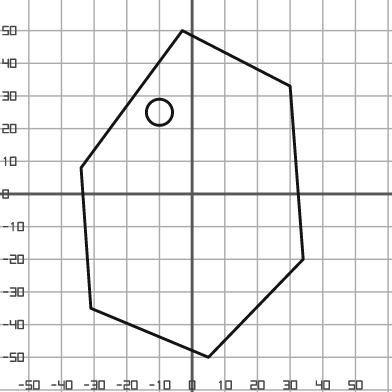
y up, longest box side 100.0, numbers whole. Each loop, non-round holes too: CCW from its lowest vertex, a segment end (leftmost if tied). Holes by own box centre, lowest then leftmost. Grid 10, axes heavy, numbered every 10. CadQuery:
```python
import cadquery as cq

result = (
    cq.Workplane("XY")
    .moveTo(5.0, -50.0)
    .lineTo(34.0, -20.0)
    .lineTo(30.0, 33.0)
    .lineTo(-3.0, 50.0)
    .lineTo(-34.0, 8.0)
    .lineTo(-31.0, -35.0)
    .close()
    .moveTo(-10.0, 25.0)
    .circle(4.0)
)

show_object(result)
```